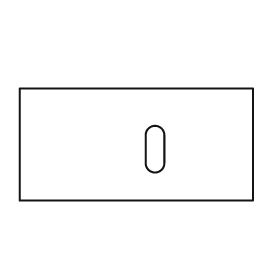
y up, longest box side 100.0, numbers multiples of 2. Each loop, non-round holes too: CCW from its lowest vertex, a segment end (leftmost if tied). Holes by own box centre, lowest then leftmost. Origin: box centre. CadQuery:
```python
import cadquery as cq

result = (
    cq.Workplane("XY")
    .moveTo(-50.0, -24.0)
    .lineTo(50.0, -24.0)
    .lineTo(50.0, 24.0)
    .lineTo(-50.0, 24.0)
    .close()
    .moveTo(4.0, -8.0)
    .threePointArc((8.0, -12.0), (12.0, -8.0))
    .lineTo(12.0, 4.0)
    .threePointArc((8.0, 8.0), (4.0, 4.0))
    .close()
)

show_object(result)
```